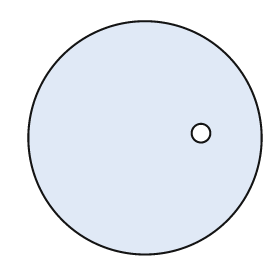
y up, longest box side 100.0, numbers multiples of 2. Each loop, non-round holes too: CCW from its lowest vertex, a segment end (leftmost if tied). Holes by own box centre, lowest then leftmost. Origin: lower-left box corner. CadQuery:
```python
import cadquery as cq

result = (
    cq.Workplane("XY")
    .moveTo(50.0, 50.0)
    .circle(50.0)
    .moveTo(74.0, 52.0)
    .circle(4.0)
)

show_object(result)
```